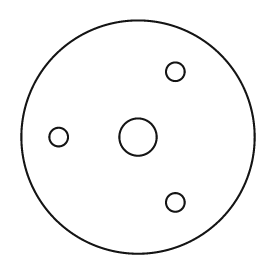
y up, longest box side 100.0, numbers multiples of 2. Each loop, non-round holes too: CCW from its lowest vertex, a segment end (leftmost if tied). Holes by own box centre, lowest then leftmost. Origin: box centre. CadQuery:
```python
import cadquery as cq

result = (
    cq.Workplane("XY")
    .moveTo(0.0, 0.0)
    .circle(50.0)
    .moveTo(16.0, -28.0)
    .circle(4.0)
    .moveTo(-34.0, 0.0)
    .circle(4.0)
    .moveTo(0.0, 0.0)
    .circle(8.0)
    .moveTo(16.0, 28.0)
    .circle(4.0)
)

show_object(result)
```